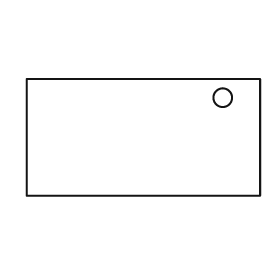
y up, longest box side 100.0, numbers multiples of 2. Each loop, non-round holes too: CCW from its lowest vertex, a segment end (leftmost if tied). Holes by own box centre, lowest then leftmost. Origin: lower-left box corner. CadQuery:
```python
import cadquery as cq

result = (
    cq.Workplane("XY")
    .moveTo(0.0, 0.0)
    .lineTo(100.0, 0.0)
    .lineTo(100.0, 50.0)
    .lineTo(0.0, 50.0)
    .close()
    .moveTo(84.0, 42.0)
    .circle(4.0)
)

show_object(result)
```